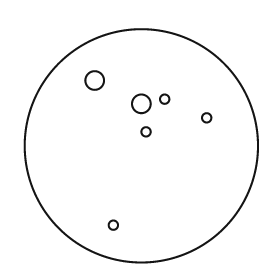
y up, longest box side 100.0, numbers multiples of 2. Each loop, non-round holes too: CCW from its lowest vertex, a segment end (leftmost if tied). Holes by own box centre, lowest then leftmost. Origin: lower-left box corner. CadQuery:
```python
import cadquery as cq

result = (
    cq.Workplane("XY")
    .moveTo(50.0, 50.0)
    .circle(50.0)
    .moveTo(38.0, 16.0)
    .circle(2.0)
    .moveTo(52.0, 56.0)
    .circle(2.0)
    .moveTo(78.0, 62.0)
    .circle(2.0)
    .moveTo(50.0, 68.0)
    .circle(4.0)
    .moveTo(60.0, 70.0)
    .circle(2.0)
    .moveTo(30.0, 78.0)
    .circle(4.0)
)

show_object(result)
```